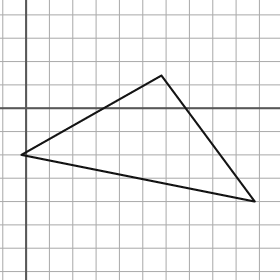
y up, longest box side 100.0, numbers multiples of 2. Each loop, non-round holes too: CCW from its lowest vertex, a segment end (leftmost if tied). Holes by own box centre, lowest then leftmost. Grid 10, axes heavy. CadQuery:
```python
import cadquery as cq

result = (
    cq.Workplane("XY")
    .moveTo(98.0, -40.0)
    .lineTo(58.0, 14.0)
    .lineTo(-2.0, -20.0)
    .close()
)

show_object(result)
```